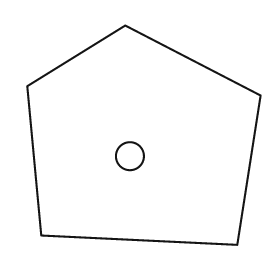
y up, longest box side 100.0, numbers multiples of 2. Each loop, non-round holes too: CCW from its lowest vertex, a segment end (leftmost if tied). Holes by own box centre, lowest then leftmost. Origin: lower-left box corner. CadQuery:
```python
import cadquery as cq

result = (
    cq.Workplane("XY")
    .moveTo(90.0, 0.0)
    .lineTo(100.0, 64.0)
    .lineTo(42.0, 94.0)
    .lineTo(0.0, 68.0)
    .lineTo(6.0, 4.0)
    .close()
    .moveTo(44.0, 38.0)
    .circle(6.0)
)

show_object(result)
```